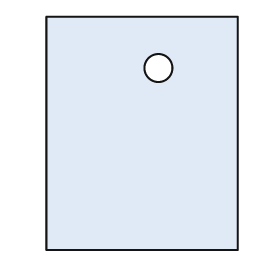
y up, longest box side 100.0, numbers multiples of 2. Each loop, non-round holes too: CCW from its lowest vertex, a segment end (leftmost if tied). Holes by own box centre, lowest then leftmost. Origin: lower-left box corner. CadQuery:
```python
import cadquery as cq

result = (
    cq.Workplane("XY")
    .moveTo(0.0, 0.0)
    .lineTo(82.0, 0.0)
    .lineTo(82.0, 100.0)
    .lineTo(0.0, 100.0)
    .close()
    .moveTo(48.0, 78.0)
    .circle(6.0)
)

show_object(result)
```